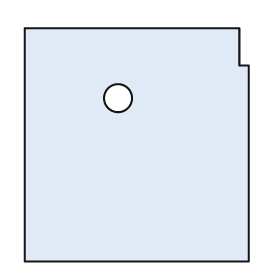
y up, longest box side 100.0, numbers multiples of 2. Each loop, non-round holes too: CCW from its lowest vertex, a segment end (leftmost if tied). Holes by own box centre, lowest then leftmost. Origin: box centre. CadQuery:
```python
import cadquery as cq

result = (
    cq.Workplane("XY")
    .moveTo(-48.0, -50.0)
    .lineTo(48.0, -50.0)
    .lineTo(48.0, 34.0)
    .lineTo(44.0, 34.0)
    .lineTo(44.0, 50.0)
    .lineTo(-48.0, 50.0)
    .close()
    .moveTo(-8.0, 20.0)
    .circle(6.0)
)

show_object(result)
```